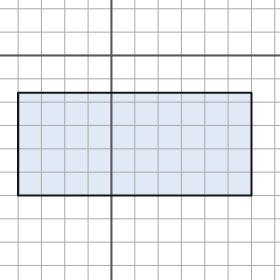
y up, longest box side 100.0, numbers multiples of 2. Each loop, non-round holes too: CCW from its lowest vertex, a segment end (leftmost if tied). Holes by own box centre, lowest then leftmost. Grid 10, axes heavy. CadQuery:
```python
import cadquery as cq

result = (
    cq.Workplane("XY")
    .moveTo(-40.0, -60.0)
    .lineTo(60.0, -60.0)
    .lineTo(60.0, -16.0)
    .lineTo(-40.0, -16.0)
    .close()
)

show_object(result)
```